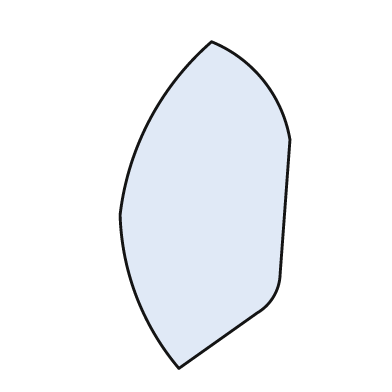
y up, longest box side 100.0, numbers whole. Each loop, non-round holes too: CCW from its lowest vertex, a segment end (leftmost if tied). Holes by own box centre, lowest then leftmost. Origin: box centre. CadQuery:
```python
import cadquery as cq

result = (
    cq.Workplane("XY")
    .moveTo(-8.0, -50.0)
    .lineTo(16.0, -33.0)
    .threePointArc((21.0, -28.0), (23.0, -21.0))
    .lineTo(26.0, 20.0)
    .threePointArc((18.0, 38.0), (2.0, 50.0))
    .threePointArc((-17.0, 26.0), (-26.0, -3.0))
    .threePointArc((-21.0, -28.0), (-8.0, -50.0))
    .close()
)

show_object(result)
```